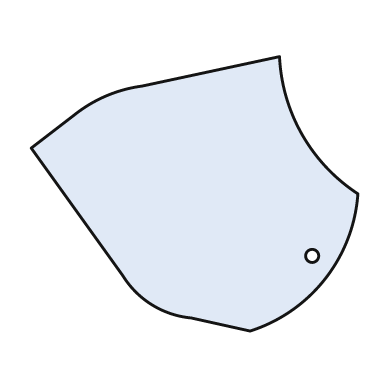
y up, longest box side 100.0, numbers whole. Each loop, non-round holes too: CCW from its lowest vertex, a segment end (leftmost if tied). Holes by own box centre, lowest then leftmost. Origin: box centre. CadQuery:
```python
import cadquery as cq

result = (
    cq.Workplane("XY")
    .moveTo(17.0, -42.0)
    .threePointArc((40.0, -26.0), (50.0, 0.0))
    .threePointArc((33.0, 18.0), (26.0, 42.0))
    .lineTo(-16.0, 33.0)
    .threePointArc((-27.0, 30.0), (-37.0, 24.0))
    .lineTo(-50.0, 14.0)
    .lineTo(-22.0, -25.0)
    .threePointArc((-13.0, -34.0), (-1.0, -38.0))
    .close()
    .moveTo(36.0, -19.0)
    .circle(2.0)
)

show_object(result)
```